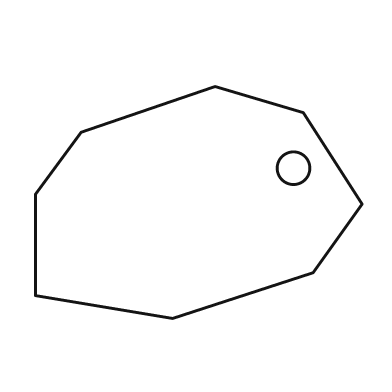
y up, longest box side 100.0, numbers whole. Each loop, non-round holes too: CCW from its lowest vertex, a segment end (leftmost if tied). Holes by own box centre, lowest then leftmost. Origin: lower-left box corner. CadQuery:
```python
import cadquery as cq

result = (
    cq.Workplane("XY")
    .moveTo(42.0, 0.0)
    .lineTo(85.0, 14.0)
    .lineTo(100.0, 35.0)
    .lineTo(82.0, 63.0)
    .lineTo(55.0, 71.0)
    .lineTo(14.0, 57.0)
    .lineTo(0.0, 38.0)
    .lineTo(0.0, 7.0)
    .close()
    .moveTo(79.0, 46.0)
    .circle(5.0)
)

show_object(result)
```